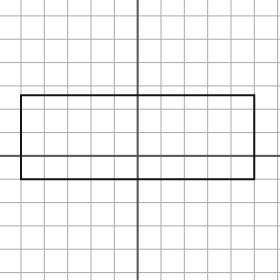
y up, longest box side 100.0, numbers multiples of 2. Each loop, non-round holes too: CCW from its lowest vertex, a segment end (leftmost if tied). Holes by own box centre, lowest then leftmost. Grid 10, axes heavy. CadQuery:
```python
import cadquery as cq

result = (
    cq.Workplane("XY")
    .moveTo(-50.0, -10.0)
    .lineTo(50.0, -10.0)
    .lineTo(50.0, 26.0)
    .lineTo(-50.0, 26.0)
    .close()
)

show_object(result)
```